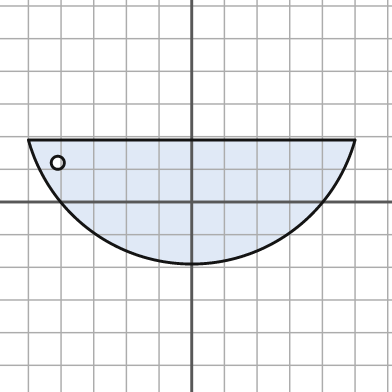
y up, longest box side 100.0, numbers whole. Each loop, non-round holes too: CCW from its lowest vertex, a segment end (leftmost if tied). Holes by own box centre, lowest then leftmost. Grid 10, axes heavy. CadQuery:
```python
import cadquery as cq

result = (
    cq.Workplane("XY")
    .moveTo(-50.0, 19.0)
    .threePointArc((0.0, -19.0), (50.0, 19.0))
    .close()
    .moveTo(-41.0, 12.0)
    .circle(2.0)
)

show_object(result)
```